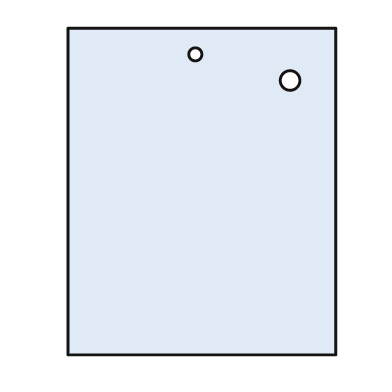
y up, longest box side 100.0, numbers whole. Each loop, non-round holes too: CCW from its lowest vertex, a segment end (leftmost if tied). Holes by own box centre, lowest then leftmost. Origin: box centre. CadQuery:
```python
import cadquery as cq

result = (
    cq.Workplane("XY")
    .moveTo(-41.0, -50.0)
    .lineTo(41.0, -50.0)
    .lineTo(41.0, 50.0)
    .lineTo(-41.0, 50.0)
    .close()
    .moveTo(27.0, 34.0)
    .circle(3.0)
    .moveTo(-2.0, 42.0)
    .circle(2.0)
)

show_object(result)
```